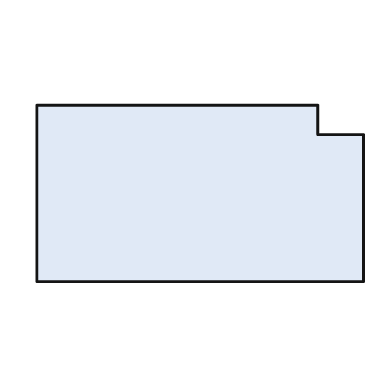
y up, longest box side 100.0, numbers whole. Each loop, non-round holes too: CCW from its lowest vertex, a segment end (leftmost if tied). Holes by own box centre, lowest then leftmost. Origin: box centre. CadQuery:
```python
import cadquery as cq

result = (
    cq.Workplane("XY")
    .moveTo(-50.0, -27.0)
    .lineTo(50.0, -27.0)
    .lineTo(50.0, 18.0)
    .lineTo(36.0, 18.0)
    .lineTo(36.0, 27.0)
    .lineTo(-50.0, 27.0)
    .close()
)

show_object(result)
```